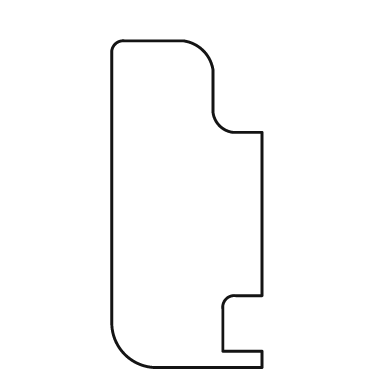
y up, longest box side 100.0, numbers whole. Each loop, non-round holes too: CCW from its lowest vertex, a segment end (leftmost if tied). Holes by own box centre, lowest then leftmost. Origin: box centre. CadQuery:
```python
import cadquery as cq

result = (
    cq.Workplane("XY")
    .moveTo(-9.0, -50.0)
    .lineTo(23.0, -50.0)
    .lineTo(23.0, -45.0)
    .lineTo(11.0, -45.0)
    .lineTo(11.0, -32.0)
    .threePointArc((12.0, -29.0), (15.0, -28.0))
    .lineTo(23.0, -28.0)
    .lineTo(23.0, 22.0)
    .lineTo(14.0, 22.0)
    .threePointArc((10.0, 24.0), (8.0, 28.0))
    .lineTo(8.0, 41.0)
    .threePointArc((5.0, 47.0), (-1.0, 50.0))
    .lineTo(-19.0, 50.0)
    .threePointArc((-22.0, 49.0), (-23.0, 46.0))
    .lineTo(-23.0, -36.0)
    .threePointArc((-19.0, -46.0), (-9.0, -50.0))
    .close()
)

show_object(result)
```